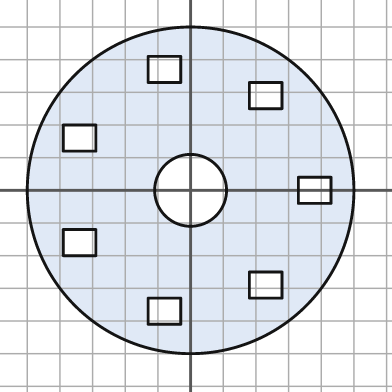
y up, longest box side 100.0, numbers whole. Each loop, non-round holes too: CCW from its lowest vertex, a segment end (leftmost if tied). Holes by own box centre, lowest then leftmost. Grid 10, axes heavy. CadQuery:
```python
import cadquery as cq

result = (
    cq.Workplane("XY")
    .moveTo(0.0, 0.0)
    .circle(50.0)
    .moveTo(-13.0, -41.0)
    .lineTo(-3.0, -41.0)
    .lineTo(-3.0, -33.0)
    .lineTo(-13.0, -33.0)
    .close()
    .moveTo(18.0, -33.0)
    .lineTo(28.0, -33.0)
    .lineTo(28.0, -25.0)
    .lineTo(18.0, -25.0)
    .close()
    .moveTo(-39.0, -20.0)
    .lineTo(-29.0, -20.0)
    .lineTo(-29.0, -12.0)
    .lineTo(-39.0, -12.0)
    .close()
    .moveTo(0.0, 0.0)
    .circle(11.0)
    .moveTo(33.0, -4.0)
    .lineTo(43.0, -4.0)
    .lineTo(43.0, 4.0)
    .lineTo(33.0, 4.0)
    .close()
    .moveTo(-39.0, 12.0)
    .lineTo(-29.0, 12.0)
    .lineTo(-29.0, 20.0)
    .lineTo(-39.0, 20.0)
    .close()
    .moveTo(18.0, 25.0)
    .lineTo(28.0, 25.0)
    .lineTo(28.0, 33.0)
    .lineTo(18.0, 33.0)
    .close()
    .moveTo(-13.0, 33.0)
    .lineTo(-3.0, 33.0)
    .lineTo(-3.0, 41.0)
    .lineTo(-13.0, 41.0)
    .close()
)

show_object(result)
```